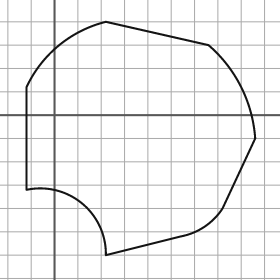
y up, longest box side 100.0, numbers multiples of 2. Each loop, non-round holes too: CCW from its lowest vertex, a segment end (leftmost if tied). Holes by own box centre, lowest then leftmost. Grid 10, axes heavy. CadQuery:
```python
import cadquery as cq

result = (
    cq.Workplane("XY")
    .moveTo(22.0, -60.0)
    .lineTo(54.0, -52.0)
    .threePointArc((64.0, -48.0), (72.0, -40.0))
    .lineTo(86.0, -10.0)
    .threePointArc((80.0, 12.0), (66.0, 30.0))
    .lineTo(22.0, 40.0)
    .threePointArc((2.0, 30.0), (-12.0, 12.0))
    .lineTo(-12.0, -32.0)
    .threePointArc((12.0, -38.0), (22.0, -60.0))
    .close()
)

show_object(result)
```